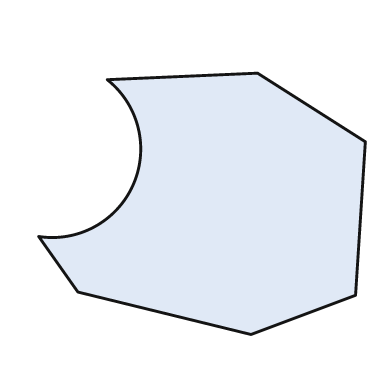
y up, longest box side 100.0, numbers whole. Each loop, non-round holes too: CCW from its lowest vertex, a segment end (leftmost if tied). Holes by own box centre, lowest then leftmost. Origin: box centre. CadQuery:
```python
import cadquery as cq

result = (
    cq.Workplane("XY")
    .moveTo(15.0, -40.0)
    .lineTo(47.0, -28.0)
    .lineTo(50.0, 19.0)
    .lineTo(17.0, 40.0)
    .lineTo(-29.0, 38.0)
    .threePointArc((-21.0, 6.0), (-50.0, -10.0))
    .lineTo(-38.0, -27.0)
    .close()
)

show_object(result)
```